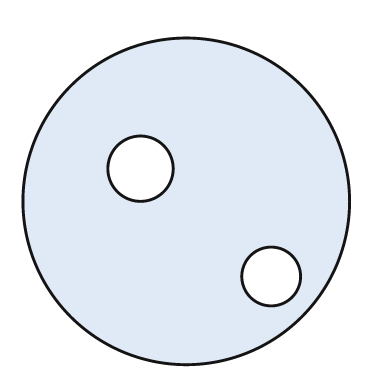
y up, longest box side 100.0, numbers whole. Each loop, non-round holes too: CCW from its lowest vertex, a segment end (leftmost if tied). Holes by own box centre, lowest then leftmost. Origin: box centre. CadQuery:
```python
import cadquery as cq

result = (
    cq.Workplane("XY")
    .moveTo(0.0, 0.0)
    .circle(50.0)
    .moveTo(26.0, -23.0)
    .circle(9.0)
    .moveTo(-14.0, 10.0)
    .circle(10.0)
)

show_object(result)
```